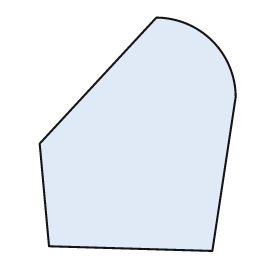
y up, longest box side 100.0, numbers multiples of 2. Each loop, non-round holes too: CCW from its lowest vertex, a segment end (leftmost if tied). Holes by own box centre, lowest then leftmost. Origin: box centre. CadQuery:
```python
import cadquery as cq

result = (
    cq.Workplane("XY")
    .moveTo(32.0, -50.0)
    .lineTo(42.0, 16.0)
    .threePointArc((32.0, 40.0), (8.0, 50.0))
    .lineTo(-42.0, -4.0)
    .lineTo(-38.0, -48.0)
    .close()
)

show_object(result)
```